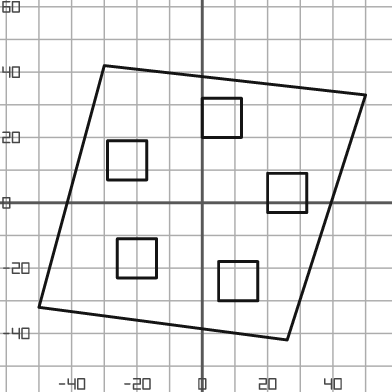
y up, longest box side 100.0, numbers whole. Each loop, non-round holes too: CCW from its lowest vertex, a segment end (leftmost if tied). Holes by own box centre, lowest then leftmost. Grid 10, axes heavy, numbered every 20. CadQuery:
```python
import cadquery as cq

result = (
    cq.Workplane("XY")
    .moveTo(26.0, -42.0)
    .lineTo(50.0, 33.0)
    .lineTo(-30.0, 42.0)
    .lineTo(-50.0, -32.0)
    .close()
    .moveTo(5.0, -30.0)
    .lineTo(17.0, -30.0)
    .lineTo(17.0, -18.0)
    .lineTo(5.0, -18.0)
    .close()
    .moveTo(-26.0, -23.0)
    .lineTo(-14.0, -23.0)
    .lineTo(-14.0, -11.0)
    .lineTo(-26.0, -11.0)
    .close()
    .moveTo(20.0, -3.0)
    .lineTo(32.0, -3.0)
    .lineTo(32.0, 9.0)
    .lineTo(20.0, 9.0)
    .close()
    .moveTo(-29.0, 7.0)
    .lineTo(-17.0, 7.0)
    .lineTo(-17.0, 19.0)
    .lineTo(-29.0, 19.0)
    .close()
    .moveTo(0.0, 20.0)
    .lineTo(12.0, 20.0)
    .lineTo(12.0, 32.0)
    .lineTo(0.0, 32.0)
    .close()
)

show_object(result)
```